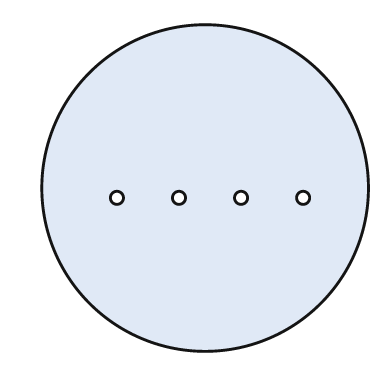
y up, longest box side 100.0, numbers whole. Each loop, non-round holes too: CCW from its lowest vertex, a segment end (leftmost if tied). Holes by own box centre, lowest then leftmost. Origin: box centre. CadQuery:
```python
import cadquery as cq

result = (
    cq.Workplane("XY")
    .moveTo(0.0, 0.0)
    .circle(50.0)
    .moveTo(-27.0, -3.0)
    .circle(2.0)
    .moveTo(-8.0, -3.0)
    .circle(2.0)
    .moveTo(11.0, -3.0)
    .circle(2.0)
    .moveTo(30.0, -3.0)
    .circle(2.0)
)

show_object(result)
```